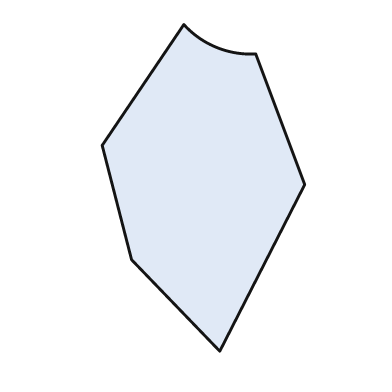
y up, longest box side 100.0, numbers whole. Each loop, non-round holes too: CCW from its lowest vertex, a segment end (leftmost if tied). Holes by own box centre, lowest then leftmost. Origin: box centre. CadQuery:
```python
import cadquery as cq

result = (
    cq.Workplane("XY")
    .moveTo(5.0, -50.0)
    .lineTo(31.0, 1.0)
    .lineTo(16.0, 41.0)
    .threePointArc((4.0, 43.0), (-6.0, 50.0))
    .lineTo(-31.0, 13.0)
    .lineTo(-22.0, -22.0)
    .close()
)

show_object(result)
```